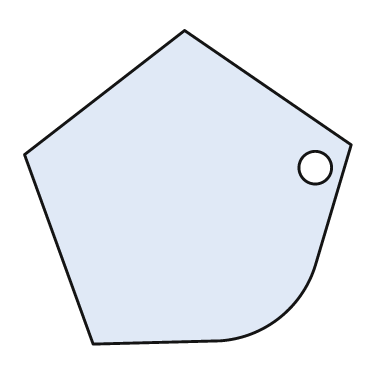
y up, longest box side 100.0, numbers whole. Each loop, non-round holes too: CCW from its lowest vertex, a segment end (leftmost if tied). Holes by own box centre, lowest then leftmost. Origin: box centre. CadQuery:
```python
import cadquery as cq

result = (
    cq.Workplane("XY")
    .moveTo(-29.0, -48.0)
    .lineTo(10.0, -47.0)
    .threePointArc((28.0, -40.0), (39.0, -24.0))
    .lineTo(50.0, 13.0)
    .lineTo(-1.0, 48.0)
    .lineTo(-50.0, 10.0)
    .close()
    .moveTo(39.0, 6.0)
    .circle(5.0)
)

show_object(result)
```